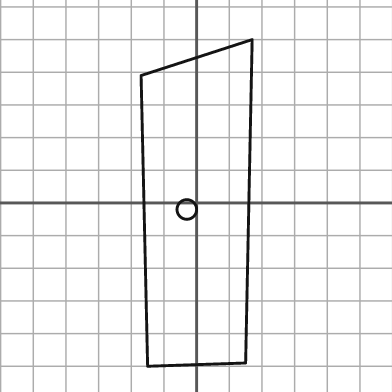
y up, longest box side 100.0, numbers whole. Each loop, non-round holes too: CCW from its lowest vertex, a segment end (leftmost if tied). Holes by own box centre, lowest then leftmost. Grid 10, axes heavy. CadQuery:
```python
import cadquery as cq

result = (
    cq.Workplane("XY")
    .moveTo(-15.0, -50.0)
    .lineTo(15.0, -49.0)
    .lineTo(17.0, 50.0)
    .lineTo(-17.0, 39.0)
    .close()
    .moveTo(-3.0, -2.0)
    .circle(3.0)
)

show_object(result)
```